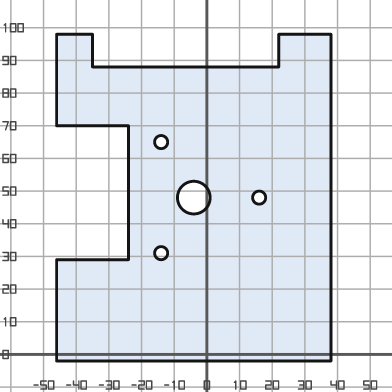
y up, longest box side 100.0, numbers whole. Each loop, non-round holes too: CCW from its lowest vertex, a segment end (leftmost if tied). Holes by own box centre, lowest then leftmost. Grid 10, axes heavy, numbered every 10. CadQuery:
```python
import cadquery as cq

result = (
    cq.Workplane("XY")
    .moveTo(-46.0, -2.0)
    .lineTo(38.0, -2.0)
    .lineTo(38.0, 98.0)
    .lineTo(22.0, 98.0)
    .lineTo(22.0, 88.0)
    .lineTo(-35.0, 88.0)
    .lineTo(-35.0, 98.0)
    .lineTo(-46.0, 98.0)
    .lineTo(-46.0, 70.0)
    .lineTo(-24.0, 70.0)
    .lineTo(-24.0, 29.0)
    .lineTo(-46.0, 29.0)
    .close()
    .moveTo(-14.0, 31.0)
    .circle(2.0)
    .moveTo(-4.0, 48.0)
    .circle(5.0)
    .moveTo(16.0, 48.0)
    .circle(2.0)
    .moveTo(-14.0, 65.0)
    .circle(2.0)
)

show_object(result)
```